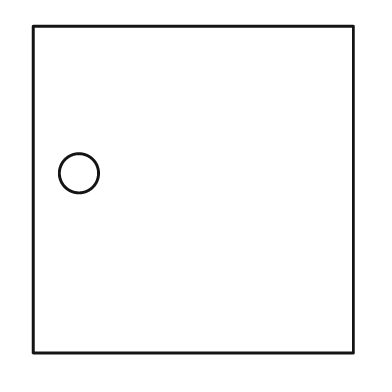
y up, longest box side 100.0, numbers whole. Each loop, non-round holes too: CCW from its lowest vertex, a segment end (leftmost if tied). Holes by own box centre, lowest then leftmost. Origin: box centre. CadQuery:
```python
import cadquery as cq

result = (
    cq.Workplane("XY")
    .moveTo(-49.0, -50.0)
    .lineTo(49.0, -50.0)
    .lineTo(49.0, 50.0)
    .lineTo(-49.0, 50.0)
    .close()
    .moveTo(-35.0, 5.0)
    .circle(6.0)
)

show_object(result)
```